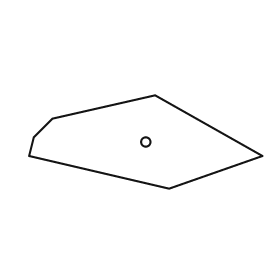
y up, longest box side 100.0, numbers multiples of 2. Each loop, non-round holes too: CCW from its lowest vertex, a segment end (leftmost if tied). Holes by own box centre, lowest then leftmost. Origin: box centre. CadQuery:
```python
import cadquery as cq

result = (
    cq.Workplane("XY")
    .moveTo(10.0, -20.0)
    .lineTo(50.0, -6.0)
    .lineTo(4.0, 20.0)
    .lineTo(-40.0, 10.0)
    .lineTo(-48.0, 2.0)
    .lineTo(-50.0, -6.0)
    .close()
    .moveTo(0.0, 0.0)
    .circle(2.0)
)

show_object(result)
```